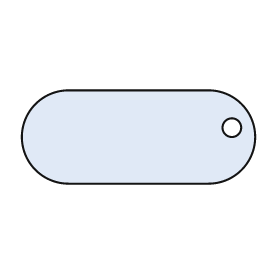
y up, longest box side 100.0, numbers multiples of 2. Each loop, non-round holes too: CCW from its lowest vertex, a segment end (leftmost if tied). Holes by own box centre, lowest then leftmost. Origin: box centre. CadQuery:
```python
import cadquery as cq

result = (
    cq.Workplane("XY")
    .moveTo(-30.0, -20.0)
    .lineTo(30.0, -20.0)
    .threePointArc((50.0, 0.0), (30.0, 20.0))
    .lineTo(-30.0, 20.0)
    .threePointArc((-50.0, 0.0), (-30.0, -20.0))
    .close()
    .moveTo(40.0, 4.0)
    .circle(4.0)
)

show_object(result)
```